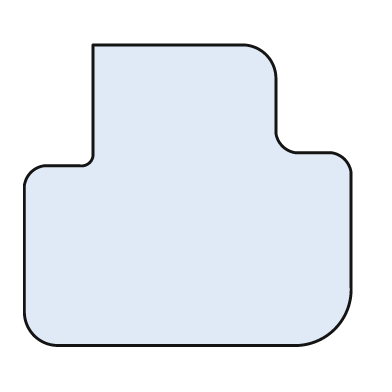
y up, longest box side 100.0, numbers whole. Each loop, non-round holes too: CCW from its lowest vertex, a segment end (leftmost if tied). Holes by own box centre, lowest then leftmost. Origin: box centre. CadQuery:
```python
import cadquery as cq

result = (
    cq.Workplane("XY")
    .moveTo(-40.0, -46.0)
    .lineTo(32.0, -46.0)
    .threePointArc((45.0, -41.0), (50.0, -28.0))
    .lineTo(50.0, 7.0)
    .threePointArc((48.0, 11.0), (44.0, 13.0))
    .lineTo(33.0, 13.0)
    .threePointArc((29.0, 15.0), (27.0, 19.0))
    .lineTo(27.0, 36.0)
    .threePointArc((24.0, 43.0), (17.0, 46.0))
    .lineTo(-29.0, 46.0)
    .lineTo(-29.0, 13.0)
    .threePointArc((-30.0, 10.0), (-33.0, 9.0))
    .lineTo(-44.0, 9.0)
    .threePointArc((-48.0, 7.0), (-50.0, 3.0))
    .lineTo(-50.0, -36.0)
    .threePointArc((-47.0, -43.0), (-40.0, -46.0))
    .close()
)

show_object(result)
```